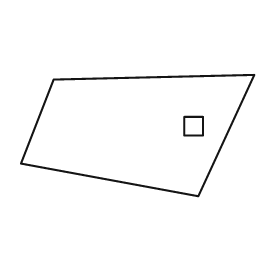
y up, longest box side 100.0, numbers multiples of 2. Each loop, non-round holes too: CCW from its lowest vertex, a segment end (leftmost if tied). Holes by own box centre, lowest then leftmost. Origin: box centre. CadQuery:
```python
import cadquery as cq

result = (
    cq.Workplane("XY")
    .moveTo(26.0, -26.0)
    .lineTo(50.0, 26.0)
    .lineTo(-36.0, 24.0)
    .lineTo(-50.0, -12.0)
    .close()
    .moveTo(20.0, 0.0)
    .lineTo(28.0, 0.0)
    .lineTo(28.0, 8.0)
    .lineTo(20.0, 8.0)
    .close()
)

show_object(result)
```